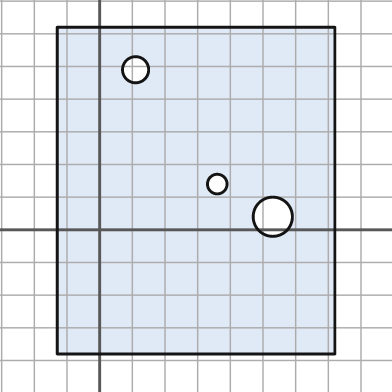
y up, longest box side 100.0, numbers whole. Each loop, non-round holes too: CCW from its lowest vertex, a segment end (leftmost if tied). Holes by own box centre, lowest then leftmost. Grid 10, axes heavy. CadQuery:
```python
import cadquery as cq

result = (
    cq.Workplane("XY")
    .moveTo(-13.0, -38.0)
    .lineTo(72.0, -38.0)
    .lineTo(72.0, 62.0)
    .lineTo(-13.0, 62.0)
    .close()
    .moveTo(53.0, 4.0)
    .circle(6.0)
    .moveTo(36.0, 14.0)
    .circle(3.0)
    .moveTo(11.0, 49.0)
    .circle(4.0)
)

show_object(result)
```